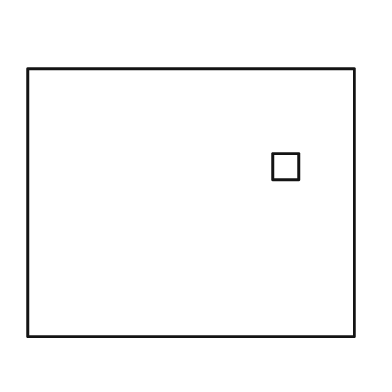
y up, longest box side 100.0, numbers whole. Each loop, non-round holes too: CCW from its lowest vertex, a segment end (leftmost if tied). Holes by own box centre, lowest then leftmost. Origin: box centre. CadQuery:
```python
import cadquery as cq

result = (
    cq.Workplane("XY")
    .moveTo(-50.0, -41.0)
    .lineTo(50.0, -41.0)
    .lineTo(50.0, 41.0)
    .lineTo(-50.0, 41.0)
    .close()
    .moveTo(25.0, 7.0)
    .lineTo(33.0, 7.0)
    .lineTo(33.0, 15.0)
    .lineTo(25.0, 15.0)
    .close()
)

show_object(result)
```